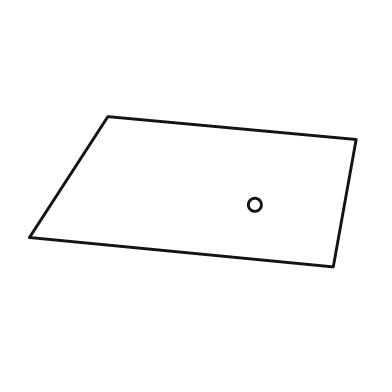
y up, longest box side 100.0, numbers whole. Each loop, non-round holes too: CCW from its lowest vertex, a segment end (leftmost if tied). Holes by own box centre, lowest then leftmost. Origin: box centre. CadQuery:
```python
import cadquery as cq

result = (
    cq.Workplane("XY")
    .moveTo(43.0, -23.0)
    .lineTo(50.0, 16.0)
    .lineTo(-26.0, 23.0)
    .lineTo(-50.0, -14.0)
    .close()
    .moveTo(19.0, -4.0)
    .circle(2.0)
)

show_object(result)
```